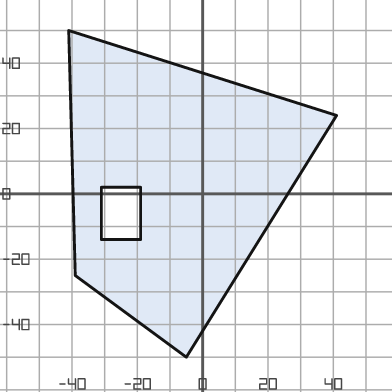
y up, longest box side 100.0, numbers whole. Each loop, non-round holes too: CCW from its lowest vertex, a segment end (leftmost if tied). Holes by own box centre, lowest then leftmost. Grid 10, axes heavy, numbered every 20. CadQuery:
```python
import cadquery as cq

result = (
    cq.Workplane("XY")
    .moveTo(-5.0, -50.0)
    .lineTo(41.0, 24.0)
    .lineTo(-41.0, 50.0)
    .lineTo(-39.0, -25.0)
    .close()
    .moveTo(-31.0, -14.0)
    .lineTo(-19.0, -14.0)
    .lineTo(-19.0, 2.0)
    .lineTo(-31.0, 2.0)
    .close()
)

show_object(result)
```